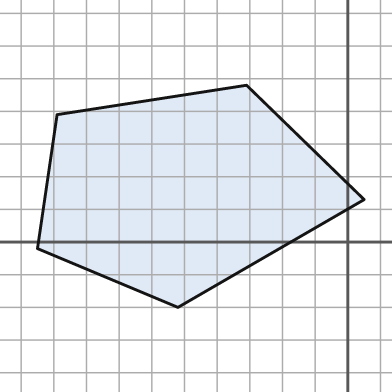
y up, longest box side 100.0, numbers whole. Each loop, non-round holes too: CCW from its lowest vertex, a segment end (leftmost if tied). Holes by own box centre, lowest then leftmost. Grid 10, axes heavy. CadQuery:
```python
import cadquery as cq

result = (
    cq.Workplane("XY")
    .moveTo(-52.0, -20.0)
    .lineTo(5.0, 13.0)
    .lineTo(-31.0, 48.0)
    .lineTo(-89.0, 39.0)
    .lineTo(-95.0, -2.0)
    .close()
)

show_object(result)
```